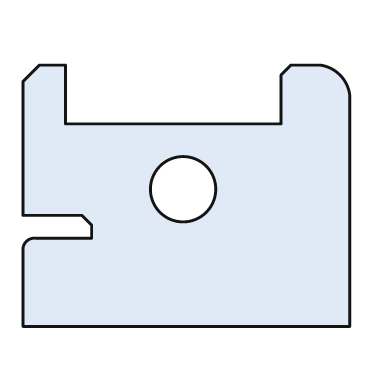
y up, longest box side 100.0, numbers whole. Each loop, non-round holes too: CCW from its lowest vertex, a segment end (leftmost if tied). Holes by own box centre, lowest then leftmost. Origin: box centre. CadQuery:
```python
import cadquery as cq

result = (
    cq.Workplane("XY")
    .moveTo(-50.0, -40.0)
    .lineTo(50.0, -40.0)
    .lineTo(50.0, 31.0)
    .threePointArc((47.0, 37.0), (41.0, 40.0))
    .lineTo(32.0, 40.0)
    .lineTo(29.0, 37.0)
    .lineTo(29.0, 22.0)
    .lineTo(-37.0, 22.0)
    .lineTo(-37.0, 40.0)
    .lineTo(-45.0, 40.0)
    .lineTo(-50.0, 35.0)
    .lineTo(-50.0, -6.0)
    .lineTo(-32.0, -6.0)
    .lineTo(-29.0, -9.0)
    .lineTo(-29.0, -13.0)
    .lineTo(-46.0, -13.0)
    .threePointArc((-49.0, -14.0), (-50.0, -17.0))
    .close()
    .moveTo(-1.0, 2.0)
    .circle(10.0)
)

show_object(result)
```